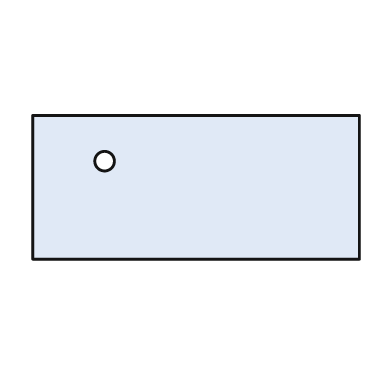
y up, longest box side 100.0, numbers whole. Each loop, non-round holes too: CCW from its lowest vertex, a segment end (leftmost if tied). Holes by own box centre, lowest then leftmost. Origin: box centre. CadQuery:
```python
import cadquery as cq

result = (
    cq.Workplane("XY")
    .moveTo(-50.0, -22.0)
    .lineTo(50.0, -22.0)
    .lineTo(50.0, 22.0)
    .lineTo(-50.0, 22.0)
    .close()
    .moveTo(-28.0, 8.0)
    .circle(3.0)
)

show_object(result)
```